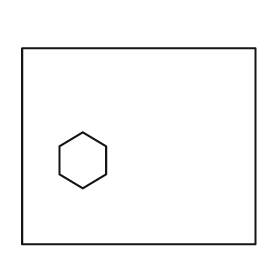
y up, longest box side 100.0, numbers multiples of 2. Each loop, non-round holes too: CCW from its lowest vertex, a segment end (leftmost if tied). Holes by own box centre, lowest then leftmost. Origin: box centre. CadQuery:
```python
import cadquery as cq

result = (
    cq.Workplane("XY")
    .moveTo(-50.0, -42.0)
    .lineTo(50.0, -42.0)
    .lineTo(50.0, 42.0)
    .lineTo(-50.0, 42.0)
    .close()
    .moveTo(-24.0, -18.0)
    .lineTo(-14.0, -12.0)
    .lineTo(-14.0, 0.0)
    .lineTo(-24.0, 6.0)
    .lineTo(-34.0, 0.0)
    .lineTo(-34.0, -12.0)
    .close()
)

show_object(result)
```